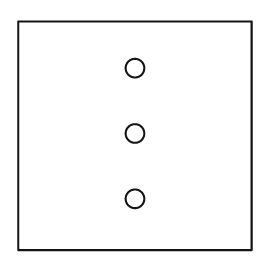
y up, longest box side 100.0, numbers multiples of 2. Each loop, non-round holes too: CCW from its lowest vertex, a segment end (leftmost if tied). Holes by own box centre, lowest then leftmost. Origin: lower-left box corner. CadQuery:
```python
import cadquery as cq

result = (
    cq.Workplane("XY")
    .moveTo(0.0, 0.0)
    .lineTo(100.0, 0.0)
    .lineTo(100.0, 98.0)
    .lineTo(0.0, 98.0)
    .close()
    .moveTo(50.0, 22.0)
    .circle(4.0)
    .moveTo(50.0, 50.0)
    .circle(4.0)
    .moveTo(50.0, 78.0)
    .circle(4.0)
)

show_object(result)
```